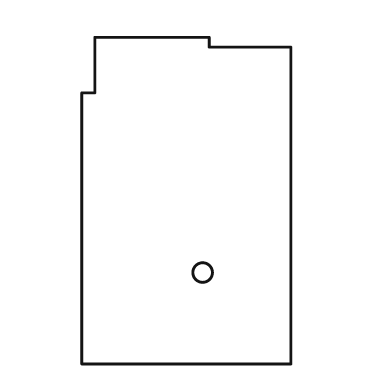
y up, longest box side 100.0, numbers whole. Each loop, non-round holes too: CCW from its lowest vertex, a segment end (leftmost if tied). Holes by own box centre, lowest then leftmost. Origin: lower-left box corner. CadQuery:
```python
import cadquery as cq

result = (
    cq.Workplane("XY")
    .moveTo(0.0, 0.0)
    .lineTo(64.0, 0.0)
    .lineTo(64.0, 97.0)
    .lineTo(39.0, 97.0)
    .lineTo(39.0, 100.0)
    .lineTo(4.0, 100.0)
    .lineTo(4.0, 83.0)
    .lineTo(0.0, 83.0)
    .close()
    .moveTo(37.0, 28.0)
    .circle(3.0)
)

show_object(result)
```